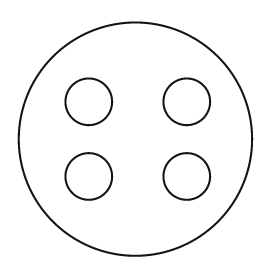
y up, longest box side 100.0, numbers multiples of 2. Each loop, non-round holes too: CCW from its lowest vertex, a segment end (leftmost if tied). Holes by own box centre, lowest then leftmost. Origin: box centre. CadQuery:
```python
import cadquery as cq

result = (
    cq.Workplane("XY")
    .moveTo(0.0, 0.0)
    .circle(50.0)
    .moveTo(-20.0, -16.0)
    .circle(10.0)
    .moveTo(22.0, -16.0)
    .circle(10.0)
    .moveTo(-20.0, 16.0)
    .circle(10.0)
    .moveTo(22.0, 16.0)
    .circle(10.0)
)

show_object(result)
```